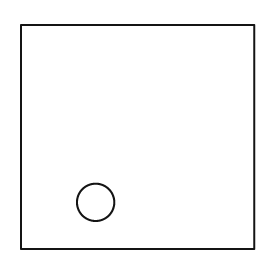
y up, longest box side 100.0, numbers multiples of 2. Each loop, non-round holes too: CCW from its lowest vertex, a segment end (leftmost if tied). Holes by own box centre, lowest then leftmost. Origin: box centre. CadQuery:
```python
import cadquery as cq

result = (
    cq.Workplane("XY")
    .moveTo(-50.0, -48.0)
    .lineTo(50.0, -48.0)
    .lineTo(50.0, 48.0)
    .lineTo(-50.0, 48.0)
    .close()
    .moveTo(-18.0, -28.0)
    .circle(8.0)
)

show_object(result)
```